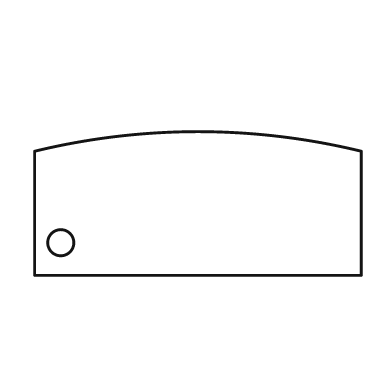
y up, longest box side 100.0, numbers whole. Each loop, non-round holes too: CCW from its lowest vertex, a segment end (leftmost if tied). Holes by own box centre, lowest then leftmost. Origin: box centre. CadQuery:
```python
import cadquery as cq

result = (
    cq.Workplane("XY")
    .moveTo(-50.0, -22.0)
    .lineTo(50.0, -22.0)
    .lineTo(50.0, 16.0)
    .threePointArc((0.0, 22.0), (-50.0, 16.0))
    .close()
    .moveTo(-42.0, -12.0)
    .circle(4.0)
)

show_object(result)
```